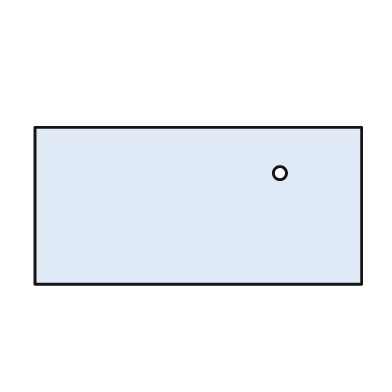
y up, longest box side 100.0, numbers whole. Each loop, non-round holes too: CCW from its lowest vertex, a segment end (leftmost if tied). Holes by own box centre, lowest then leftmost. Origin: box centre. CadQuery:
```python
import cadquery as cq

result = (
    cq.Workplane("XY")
    .moveTo(-50.0, -24.0)
    .lineTo(50.0, -24.0)
    .lineTo(50.0, 24.0)
    .lineTo(-50.0, 24.0)
    .close()
    .moveTo(25.0, 10.0)
    .circle(2.0)
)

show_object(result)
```